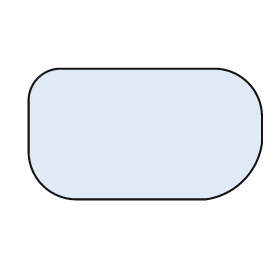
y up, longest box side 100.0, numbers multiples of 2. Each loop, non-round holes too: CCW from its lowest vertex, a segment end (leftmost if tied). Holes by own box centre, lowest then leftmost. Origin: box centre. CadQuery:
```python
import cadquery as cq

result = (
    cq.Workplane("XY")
    .moveTo(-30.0, -28.0)
    .lineTo(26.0, -28.0)
    .threePointArc((42.0, -20.0), (50.0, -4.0))
    .lineTo(50.0, 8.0)
    .threePointArc((44.0, 22.0), (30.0, 28.0))
    .lineTo(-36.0, 28.0)
    .threePointArc((-46.0, 24.0), (-50.0, 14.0))
    .lineTo(-50.0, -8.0)
    .threePointArc((-44.0, -22.0), (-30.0, -28.0))
    .close()
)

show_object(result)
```